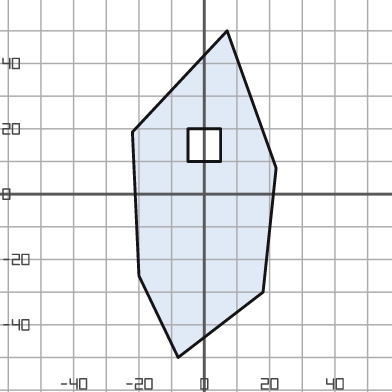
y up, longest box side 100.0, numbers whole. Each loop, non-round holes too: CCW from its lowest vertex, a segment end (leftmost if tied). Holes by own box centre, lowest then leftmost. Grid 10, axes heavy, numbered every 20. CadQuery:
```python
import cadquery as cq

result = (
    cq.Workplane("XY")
    .moveTo(-8.0, -50.0)
    .lineTo(18.0, -30.0)
    .lineTo(22.0, 8.0)
    .lineTo(7.0, 50.0)
    .lineTo(-22.0, 19.0)
    .lineTo(-20.0, -25.0)
    .close()
    .moveTo(-5.0, 10.0)
    .lineTo(5.0, 10.0)
    .lineTo(5.0, 20.0)
    .lineTo(-5.0, 20.0)
    .close()
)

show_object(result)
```